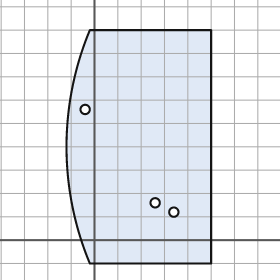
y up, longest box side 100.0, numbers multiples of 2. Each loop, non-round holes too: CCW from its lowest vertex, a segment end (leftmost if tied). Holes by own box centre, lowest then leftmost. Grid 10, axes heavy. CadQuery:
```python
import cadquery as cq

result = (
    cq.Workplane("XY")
    .moveTo(-2.0, -10.0)
    .lineTo(50.0, -10.0)
    .lineTo(50.0, 90.0)
    .lineTo(-2.0, 90.0)
    .threePointArc((-12.0, 40.0), (-2.0, -10.0))
    .close()
    .moveTo(34.0, 12.0)
    .circle(2.0)
    .moveTo(26.0, 16.0)
    .circle(2.0)
    .moveTo(-4.0, 56.0)
    .circle(2.0)
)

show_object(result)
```